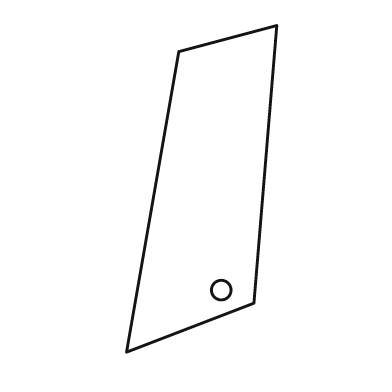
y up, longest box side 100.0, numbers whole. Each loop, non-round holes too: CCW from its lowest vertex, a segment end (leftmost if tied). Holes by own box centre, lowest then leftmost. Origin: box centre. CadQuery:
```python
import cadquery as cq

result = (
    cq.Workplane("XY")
    .moveTo(-23.0, -50.0)
    .lineTo(16.0, -35.0)
    .lineTo(23.0, 50.0)
    .lineTo(-7.0, 42.0)
    .close()
    .moveTo(6.0, -31.0)
    .circle(3.0)
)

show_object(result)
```